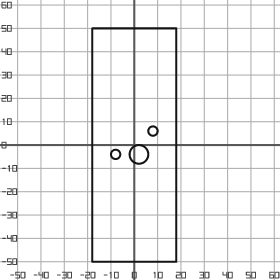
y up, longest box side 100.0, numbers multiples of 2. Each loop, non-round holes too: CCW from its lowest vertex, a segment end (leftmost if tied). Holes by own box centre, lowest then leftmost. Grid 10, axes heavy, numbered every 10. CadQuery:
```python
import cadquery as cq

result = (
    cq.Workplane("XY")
    .moveTo(-18.0, -50.0)
    .lineTo(18.0, -50.0)
    .lineTo(18.0, 50.0)
    .lineTo(-18.0, 50.0)
    .close()
    .moveTo(-8.0, -4.0)
    .circle(2.0)
    .moveTo(2.0, -4.0)
    .circle(4.0)
    .moveTo(8.0, 6.0)
    .circle(2.0)
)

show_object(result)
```